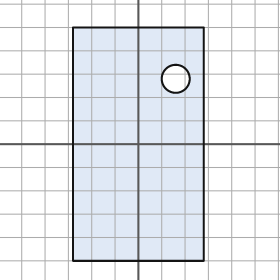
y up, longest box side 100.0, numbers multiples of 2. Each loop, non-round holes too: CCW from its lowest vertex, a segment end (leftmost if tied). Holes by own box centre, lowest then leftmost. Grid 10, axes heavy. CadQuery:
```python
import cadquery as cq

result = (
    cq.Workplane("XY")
    .moveTo(-28.0, -50.0)
    .lineTo(28.0, -50.0)
    .lineTo(28.0, 50.0)
    .lineTo(-28.0, 50.0)
    .close()
    .moveTo(16.0, 28.0)
    .circle(6.0)
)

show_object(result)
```